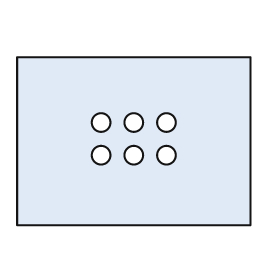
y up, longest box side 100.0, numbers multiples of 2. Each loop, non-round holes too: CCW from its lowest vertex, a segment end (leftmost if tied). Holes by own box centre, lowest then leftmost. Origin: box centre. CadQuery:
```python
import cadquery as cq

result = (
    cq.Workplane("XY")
    .moveTo(-50.0, -36.0)
    .lineTo(50.0, -36.0)
    .lineTo(50.0, 36.0)
    .lineTo(-50.0, 36.0)
    .close()
    .moveTo(-14.0, -6.0)
    .circle(4.0)
    .moveTo(0.0, -6.0)
    .circle(4.0)
    .moveTo(14.0, -6.0)
    .circle(4.0)
    .moveTo(-14.0, 8.0)
    .circle(4.0)
    .moveTo(0.0, 8.0)
    .circle(4.0)
    .moveTo(14.0, 8.0)
    .circle(4.0)
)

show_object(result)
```